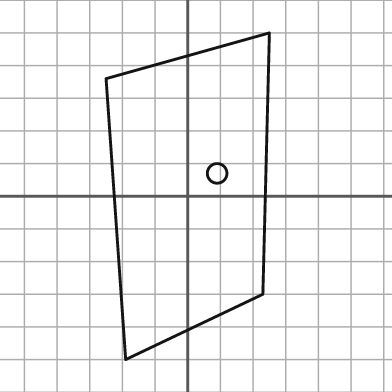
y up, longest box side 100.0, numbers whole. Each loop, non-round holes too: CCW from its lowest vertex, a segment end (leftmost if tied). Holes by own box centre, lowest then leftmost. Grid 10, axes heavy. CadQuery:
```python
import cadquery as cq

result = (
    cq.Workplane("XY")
    .moveTo(-19.0, -50.0)
    .lineTo(23.0, -30.0)
    .lineTo(25.0, 50.0)
    .lineTo(-25.0, 36.0)
    .close()
    .moveTo(9.0, 7.0)
    .circle(3.0)
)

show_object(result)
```